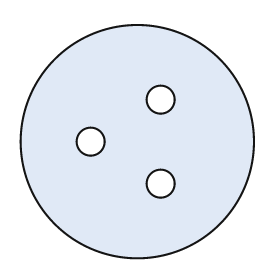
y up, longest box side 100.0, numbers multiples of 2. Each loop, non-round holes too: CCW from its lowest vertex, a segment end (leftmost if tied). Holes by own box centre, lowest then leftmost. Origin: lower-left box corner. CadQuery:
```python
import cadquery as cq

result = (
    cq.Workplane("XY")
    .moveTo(50.0, 50.0)
    .circle(50.0)
    .moveTo(60.0, 32.0)
    .circle(6.0)
    .moveTo(30.0, 50.0)
    .circle(6.0)
    .moveTo(60.0, 68.0)
    .circle(6.0)
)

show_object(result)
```